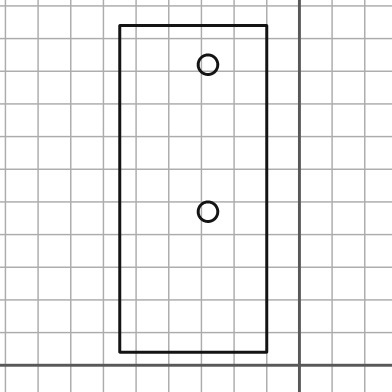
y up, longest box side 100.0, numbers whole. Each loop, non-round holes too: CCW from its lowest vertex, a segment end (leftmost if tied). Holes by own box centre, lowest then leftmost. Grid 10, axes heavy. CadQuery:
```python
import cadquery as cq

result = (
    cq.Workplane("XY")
    .moveTo(-55.0, 4.0)
    .lineTo(-10.0, 4.0)
    .lineTo(-10.0, 104.0)
    .lineTo(-55.0, 104.0)
    .close()
    .moveTo(-28.0, 47.0)
    .circle(3.0)
    .moveTo(-28.0, 92.0)
    .circle(3.0)
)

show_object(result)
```